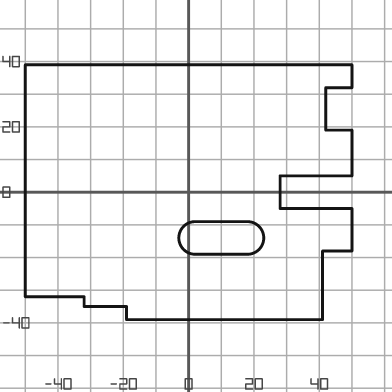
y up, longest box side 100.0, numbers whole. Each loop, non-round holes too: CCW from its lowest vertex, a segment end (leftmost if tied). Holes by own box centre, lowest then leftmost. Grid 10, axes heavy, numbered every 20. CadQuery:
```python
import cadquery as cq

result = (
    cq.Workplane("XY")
    .moveTo(-19.0, -39.0)
    .lineTo(41.0, -39.0)
    .lineTo(41.0, -18.0)
    .lineTo(50.0, -18.0)
    .lineTo(50.0, -5.0)
    .lineTo(28.0, -5.0)
    .lineTo(28.0, 5.0)
    .lineTo(50.0, 5.0)
    .lineTo(50.0, 19.0)
    .lineTo(42.0, 19.0)
    .lineTo(42.0, 32.0)
    .lineTo(50.0, 32.0)
    .lineTo(50.0, 39.0)
    .lineTo(-50.0, 39.0)
    .lineTo(-50.0, -32.0)
    .lineTo(-32.0, -32.0)
    .lineTo(-32.0, -35.0)
    .lineTo(-19.0, -35.0)
    .close()
    .moveTo(2.0, -19.0)
    .lineTo(18.0, -19.0)
    .threePointArc((23.0, -14.0), (18.0, -9.0))
    .lineTo(2.0, -9.0)
    .threePointArc((-3.0, -14.0), (2.0, -19.0))
    .close()
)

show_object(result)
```